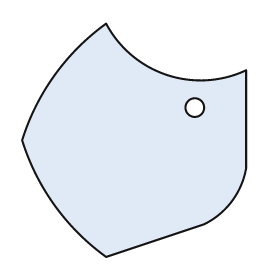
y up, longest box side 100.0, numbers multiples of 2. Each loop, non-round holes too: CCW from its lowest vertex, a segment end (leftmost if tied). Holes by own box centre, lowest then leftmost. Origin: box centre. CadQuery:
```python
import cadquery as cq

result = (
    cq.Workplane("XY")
    .moveTo(-12.0, -50.0)
    .lineTo(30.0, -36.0)
    .threePointArc((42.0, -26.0), (48.0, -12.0))
    .lineTo(48.0, 30.0)
    .threePointArc((14.0, 28.0), (-12.0, 50.0))
    .threePointArc((-34.0, 28.0), (-48.0, 0.0))
    .threePointArc((-34.0, -28.0), (-12.0, -50.0))
    .close()
    .moveTo(26.0, 14.0)
    .circle(4.0)
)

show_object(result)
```